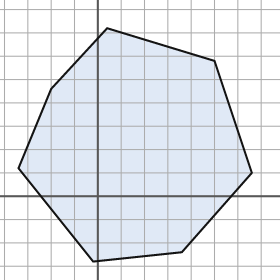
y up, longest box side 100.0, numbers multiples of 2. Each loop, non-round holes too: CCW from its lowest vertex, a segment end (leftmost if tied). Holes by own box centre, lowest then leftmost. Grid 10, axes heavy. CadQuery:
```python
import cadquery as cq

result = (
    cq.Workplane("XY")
    .moveTo(-2.0, -28.0)
    .lineTo(36.0, -24.0)
    .lineTo(66.0, 10.0)
    .lineTo(50.0, 58.0)
    .lineTo(4.0, 72.0)
    .lineTo(-20.0, 46.0)
    .lineTo(-34.0, 12.0)
    .close()
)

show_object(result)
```